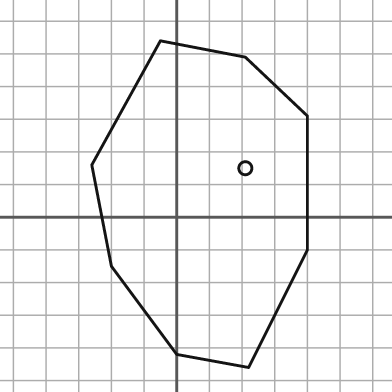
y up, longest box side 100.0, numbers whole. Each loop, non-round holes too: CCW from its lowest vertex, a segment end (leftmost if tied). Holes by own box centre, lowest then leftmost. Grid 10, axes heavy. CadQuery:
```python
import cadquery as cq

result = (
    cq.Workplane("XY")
    .moveTo(22.0, -46.0)
    .lineTo(40.0, -10.0)
    .lineTo(40.0, 31.0)
    .lineTo(21.0, 49.0)
    .lineTo(-5.0, 54.0)
    .lineTo(-26.0, 16.0)
    .lineTo(-20.0, -15.0)
    .lineTo(0.0, -42.0)
    .close()
    .moveTo(21.0, 15.0)
    .circle(2.0)
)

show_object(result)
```